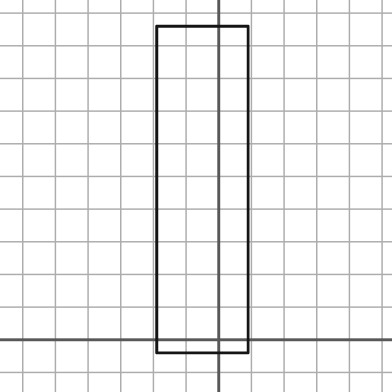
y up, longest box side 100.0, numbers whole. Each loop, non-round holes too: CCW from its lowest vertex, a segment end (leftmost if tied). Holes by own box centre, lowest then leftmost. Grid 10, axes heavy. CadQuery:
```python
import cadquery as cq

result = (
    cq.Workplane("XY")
    .moveTo(-19.0, -4.0)
    .lineTo(9.0, -4.0)
    .lineTo(9.0, 96.0)
    .lineTo(-19.0, 96.0)
    .close()
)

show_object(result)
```